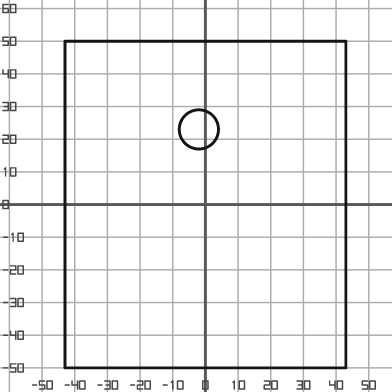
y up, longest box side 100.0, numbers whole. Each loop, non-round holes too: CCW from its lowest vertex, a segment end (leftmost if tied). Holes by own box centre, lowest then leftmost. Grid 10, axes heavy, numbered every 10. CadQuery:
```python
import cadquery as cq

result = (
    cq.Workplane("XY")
    .moveTo(-43.0, -50.0)
    .lineTo(43.0, -50.0)
    .lineTo(43.0, 50.0)
    .lineTo(-43.0, 50.0)
    .close()
    .moveTo(-2.0, 23.0)
    .circle(6.0)
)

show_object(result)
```